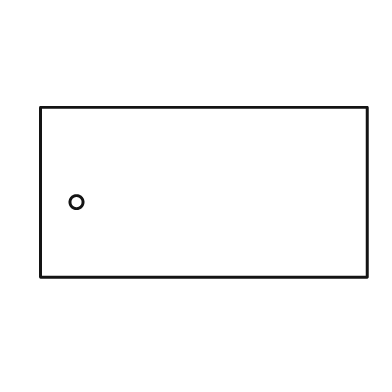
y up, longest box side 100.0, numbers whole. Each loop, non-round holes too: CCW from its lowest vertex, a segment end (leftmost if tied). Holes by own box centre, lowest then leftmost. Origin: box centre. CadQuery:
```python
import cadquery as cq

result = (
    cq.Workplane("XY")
    .moveTo(-50.0, -26.0)
    .lineTo(50.0, -26.0)
    .lineTo(50.0, 26.0)
    .lineTo(-50.0, 26.0)
    .close()
    .moveTo(-39.0, -3.0)
    .circle(2.0)
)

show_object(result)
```